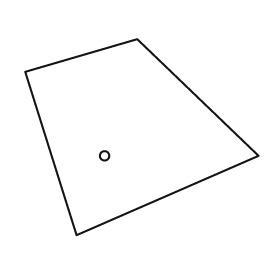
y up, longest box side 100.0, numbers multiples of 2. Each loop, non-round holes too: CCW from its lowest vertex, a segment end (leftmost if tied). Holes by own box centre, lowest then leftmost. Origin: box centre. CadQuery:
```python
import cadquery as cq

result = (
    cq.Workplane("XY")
    .moveTo(-28.0, -42.0)
    .lineTo(50.0, -8.0)
    .lineTo(-2.0, 42.0)
    .lineTo(-50.0, 28.0)
    .close()
    .moveTo(-16.0, -8.0)
    .circle(2.0)
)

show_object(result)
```